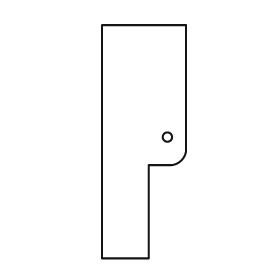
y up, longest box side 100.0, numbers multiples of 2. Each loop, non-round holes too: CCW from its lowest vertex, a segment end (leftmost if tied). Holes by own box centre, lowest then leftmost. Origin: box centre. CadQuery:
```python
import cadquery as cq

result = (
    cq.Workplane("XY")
    .moveTo(-18.0, -50.0)
    .lineTo(2.0, -50.0)
    .lineTo(2.0, -10.0)
    .lineTo(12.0, -10.0)
    .threePointArc((16.0, -8.0), (18.0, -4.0))
    .lineTo(18.0, 50.0)
    .lineTo(-18.0, 50.0)
    .close()
    .moveTo(10.0, 2.0)
    .circle(2.0)
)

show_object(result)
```